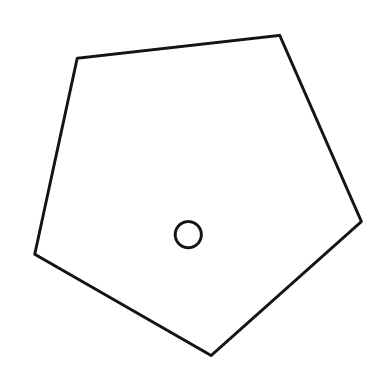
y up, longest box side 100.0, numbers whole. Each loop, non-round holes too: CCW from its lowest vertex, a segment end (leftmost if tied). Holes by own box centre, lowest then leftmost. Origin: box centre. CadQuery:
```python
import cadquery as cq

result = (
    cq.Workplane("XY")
    .moveTo(4.0, -49.0)
    .lineTo(50.0, -8.0)
    .lineTo(25.0, 49.0)
    .lineTo(-37.0, 42.0)
    .lineTo(-50.0, -18.0)
    .close()
    .moveTo(-3.0, -12.0)
    .circle(4.0)
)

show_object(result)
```